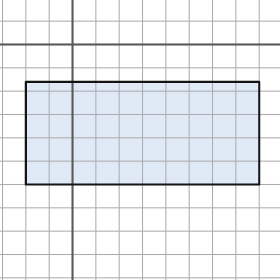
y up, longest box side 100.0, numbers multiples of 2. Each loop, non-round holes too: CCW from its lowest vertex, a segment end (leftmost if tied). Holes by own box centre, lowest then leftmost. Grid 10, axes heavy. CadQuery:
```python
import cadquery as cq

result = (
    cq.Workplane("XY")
    .moveTo(-20.0, -60.0)
    .lineTo(80.0, -60.0)
    .lineTo(80.0, -16.0)
    .lineTo(-20.0, -16.0)
    .close()
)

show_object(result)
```